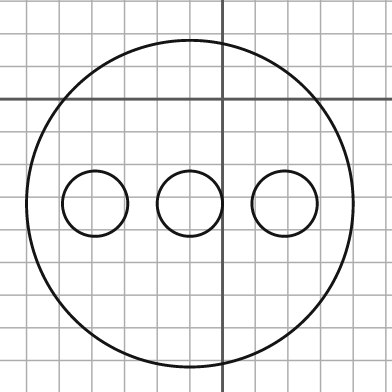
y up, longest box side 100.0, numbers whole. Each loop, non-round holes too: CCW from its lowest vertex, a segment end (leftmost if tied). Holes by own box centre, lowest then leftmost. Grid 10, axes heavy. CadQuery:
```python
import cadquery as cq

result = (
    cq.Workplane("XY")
    .moveTo(-10.0, -32.0)
    .circle(50.0)
    .moveTo(-39.0, -32.0)
    .circle(10.0)
    .moveTo(-10.0, -32.0)
    .circle(10.0)
    .moveTo(19.0, -32.0)
    .circle(10.0)
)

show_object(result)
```